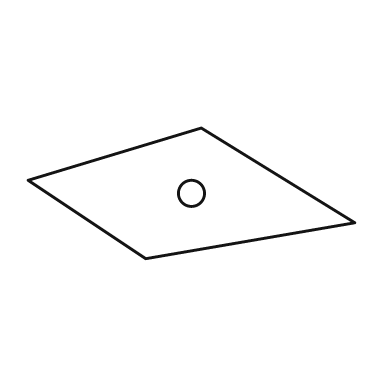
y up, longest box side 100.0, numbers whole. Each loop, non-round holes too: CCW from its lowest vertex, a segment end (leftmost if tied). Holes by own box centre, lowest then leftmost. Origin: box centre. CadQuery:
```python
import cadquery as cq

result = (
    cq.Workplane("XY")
    .moveTo(-14.0, -20.0)
    .lineTo(50.0, -9.0)
    .lineTo(3.0, 20.0)
    .lineTo(-50.0, 4.0)
    .close()
    .moveTo(0.0, 0.0)
    .circle(4.0)
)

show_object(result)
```